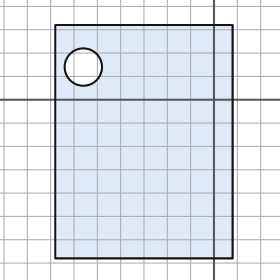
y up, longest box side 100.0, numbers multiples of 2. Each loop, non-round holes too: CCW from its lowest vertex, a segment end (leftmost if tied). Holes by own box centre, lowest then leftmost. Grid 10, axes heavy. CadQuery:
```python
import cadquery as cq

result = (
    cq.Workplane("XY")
    .moveTo(-68.0, -68.0)
    .lineTo(8.0, -68.0)
    .lineTo(8.0, 32.0)
    .lineTo(-68.0, 32.0)
    .close()
    .moveTo(-56.0, 14.0)
    .circle(8.0)
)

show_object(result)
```